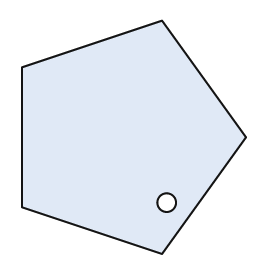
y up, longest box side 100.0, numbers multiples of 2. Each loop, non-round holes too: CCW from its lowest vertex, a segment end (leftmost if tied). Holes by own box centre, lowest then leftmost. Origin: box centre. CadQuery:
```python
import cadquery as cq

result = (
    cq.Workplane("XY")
    .moveTo(12.0, -50.0)
    .lineTo(48.0, 0.0)
    .lineTo(12.0, 50.0)
    .lineTo(-48.0, 30.0)
    .lineTo(-48.0, -30.0)
    .close()
    .moveTo(14.0, -28.0)
    .circle(4.0)
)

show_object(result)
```